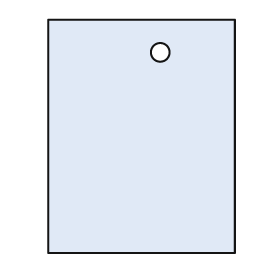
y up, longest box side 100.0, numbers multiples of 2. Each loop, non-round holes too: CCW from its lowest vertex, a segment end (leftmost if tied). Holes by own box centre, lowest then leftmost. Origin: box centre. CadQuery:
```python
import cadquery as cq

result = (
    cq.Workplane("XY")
    .moveTo(-40.0, -50.0)
    .lineTo(40.0, -50.0)
    .lineTo(40.0, 50.0)
    .lineTo(-40.0, 50.0)
    .close()
    .moveTo(8.0, 36.0)
    .circle(4.0)
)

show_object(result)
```